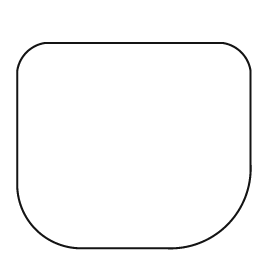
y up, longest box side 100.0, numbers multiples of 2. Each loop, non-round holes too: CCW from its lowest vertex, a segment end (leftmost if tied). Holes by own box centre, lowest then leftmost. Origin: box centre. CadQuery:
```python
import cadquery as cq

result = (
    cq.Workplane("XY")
    .moveTo(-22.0, -44.0)
    .lineTo(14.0, -44.0)
    .threePointArc((40.0, -34.0), (50.0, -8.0))
    .lineTo(50.0, 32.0)
    .threePointArc((46.0, 40.0), (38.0, 44.0))
    .lineTo(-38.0, 44.0)
    .threePointArc((-46.0, 40.0), (-50.0, 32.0))
    .lineTo(-50.0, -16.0)
    .threePointArc((-42.0, -36.0), (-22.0, -44.0))
    .close()
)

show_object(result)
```